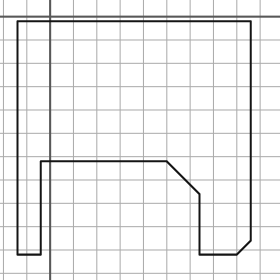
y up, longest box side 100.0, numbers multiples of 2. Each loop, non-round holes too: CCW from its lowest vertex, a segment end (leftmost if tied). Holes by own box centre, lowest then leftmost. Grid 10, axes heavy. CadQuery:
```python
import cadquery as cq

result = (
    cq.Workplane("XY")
    .moveTo(-14.0, -102.0)
    .lineTo(-4.0, -102.0)
    .lineTo(-4.0, -62.0)
    .lineTo(50.0, -62.0)
    .lineTo(64.0, -76.0)
    .lineTo(64.0, -102.0)
    .lineTo(80.0, -102.0)
    .lineTo(86.0, -96.0)
    .lineTo(86.0, -2.0)
    .lineTo(-14.0, -2.0)
    .close()
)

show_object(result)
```